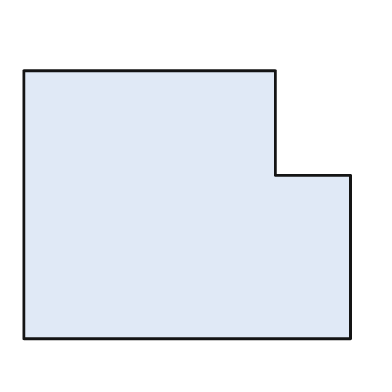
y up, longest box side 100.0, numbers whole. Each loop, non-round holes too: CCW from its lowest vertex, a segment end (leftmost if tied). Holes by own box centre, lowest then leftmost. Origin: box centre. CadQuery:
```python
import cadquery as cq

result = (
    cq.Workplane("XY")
    .moveTo(-50.0, -41.0)
    .lineTo(50.0, -41.0)
    .lineTo(50.0, 9.0)
    .lineTo(27.0, 9.0)
    .lineTo(27.0, 41.0)
    .lineTo(-50.0, 41.0)
    .close()
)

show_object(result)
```